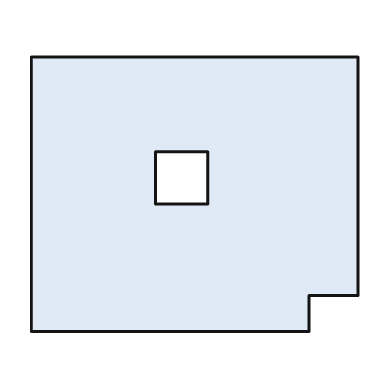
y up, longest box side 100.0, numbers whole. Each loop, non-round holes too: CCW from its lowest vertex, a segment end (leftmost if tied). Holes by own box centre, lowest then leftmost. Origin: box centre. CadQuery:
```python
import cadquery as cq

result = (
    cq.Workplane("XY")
    .moveTo(-50.0, -42.0)
    .lineTo(35.0, -42.0)
    .lineTo(35.0, -31.0)
    .lineTo(50.0, -31.0)
    .lineTo(50.0, 42.0)
    .lineTo(-50.0, 42.0)
    .close()
    .moveTo(-12.0, -3.0)
    .lineTo(4.0, -3.0)
    .lineTo(4.0, 13.0)
    .lineTo(-12.0, 13.0)
    .close()
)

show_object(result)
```